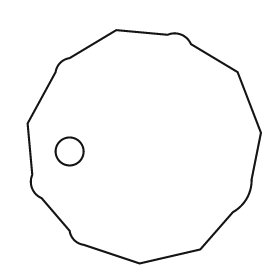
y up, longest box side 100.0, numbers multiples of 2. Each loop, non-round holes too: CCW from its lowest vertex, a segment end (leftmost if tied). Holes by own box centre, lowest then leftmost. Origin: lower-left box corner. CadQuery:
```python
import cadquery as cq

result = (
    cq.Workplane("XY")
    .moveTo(48.0, 0.0)
    .lineTo(74.0, 6.0)
    .lineTo(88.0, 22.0)
    .threePointArc((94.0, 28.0), (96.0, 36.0))
    .lineTo(100.0, 56.0)
    .lineTo(90.0, 82.0)
    .lineTo(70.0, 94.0)
    .threePointArc((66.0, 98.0), (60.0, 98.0))
    .lineTo(38.0, 100.0)
    .lineTo(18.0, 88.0)
    .threePointArc((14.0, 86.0), (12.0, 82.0))
    .lineTo(0.0, 60.0)
    .lineTo(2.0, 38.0)
    .threePointArc((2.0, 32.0), (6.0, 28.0))
    .lineTo(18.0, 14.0)
    .threePointArc((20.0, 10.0), (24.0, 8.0))
    .close()
    .moveTo(18.0, 48.0)
    .circle(6.0)
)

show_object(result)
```